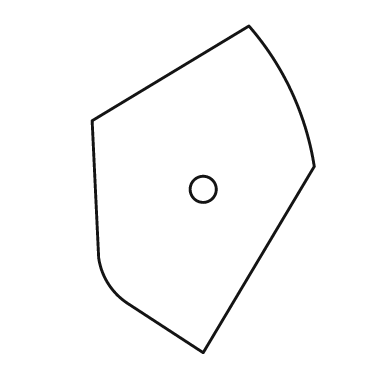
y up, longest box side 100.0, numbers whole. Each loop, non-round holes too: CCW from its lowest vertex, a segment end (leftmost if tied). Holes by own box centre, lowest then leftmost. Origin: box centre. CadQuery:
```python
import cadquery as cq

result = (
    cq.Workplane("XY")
    .moveTo(0.0, -50.0)
    .lineTo(34.0, 7.0)
    .threePointArc((27.0, 30.0), (14.0, 50.0))
    .lineTo(-34.0, 21.0)
    .lineTo(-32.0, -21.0)
    .threePointArc((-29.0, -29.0), (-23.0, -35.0))
    .close()
    .moveTo(0.0, 0.0)
    .circle(4.0)
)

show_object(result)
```